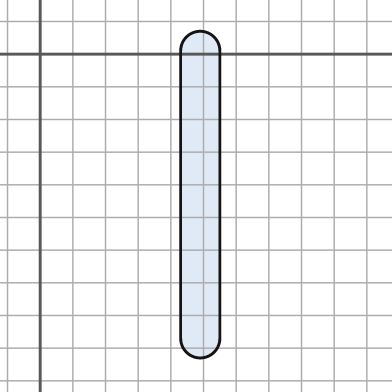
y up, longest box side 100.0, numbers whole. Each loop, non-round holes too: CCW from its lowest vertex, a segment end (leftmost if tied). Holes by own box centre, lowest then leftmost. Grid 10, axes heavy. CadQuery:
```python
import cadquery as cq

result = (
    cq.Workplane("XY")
    .moveTo(43.0, -87.0)
    .threePointArc((49.0, -93.0), (55.0, -87.0))
    .lineTo(55.0, 1.0)
    .threePointArc((49.0, 7.0), (43.0, 1.0))
    .close()
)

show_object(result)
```